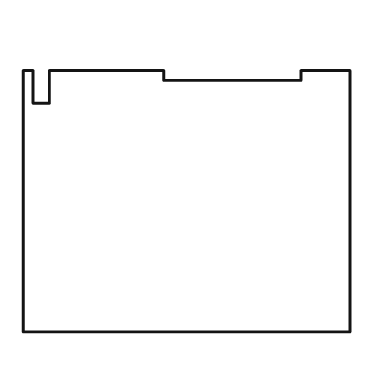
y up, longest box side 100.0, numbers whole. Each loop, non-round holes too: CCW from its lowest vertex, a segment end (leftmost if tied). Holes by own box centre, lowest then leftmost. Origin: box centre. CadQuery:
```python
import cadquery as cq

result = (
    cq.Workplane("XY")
    .moveTo(-50.0, -40.0)
    .lineTo(50.0, -40.0)
    .lineTo(50.0, 40.0)
    .lineTo(35.0, 40.0)
    .lineTo(35.0, 37.0)
    .lineTo(-7.0, 37.0)
    .lineTo(-7.0, 40.0)
    .lineTo(-42.0, 40.0)
    .lineTo(-42.0, 30.0)
    .lineTo(-47.0, 30.0)
    .lineTo(-47.0, 40.0)
    .lineTo(-50.0, 40.0)
    .close()
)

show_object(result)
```